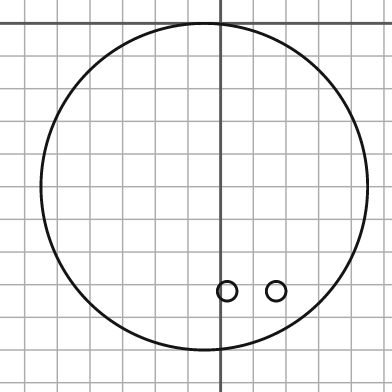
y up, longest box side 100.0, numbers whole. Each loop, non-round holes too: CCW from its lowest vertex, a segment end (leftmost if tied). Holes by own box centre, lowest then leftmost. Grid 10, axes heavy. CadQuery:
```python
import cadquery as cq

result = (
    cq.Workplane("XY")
    .moveTo(-5.0, -50.0)
    .circle(50.0)
    .moveTo(2.0, -82.0)
    .circle(3.0)
    .moveTo(17.0, -82.0)
    .circle(3.0)
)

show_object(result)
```